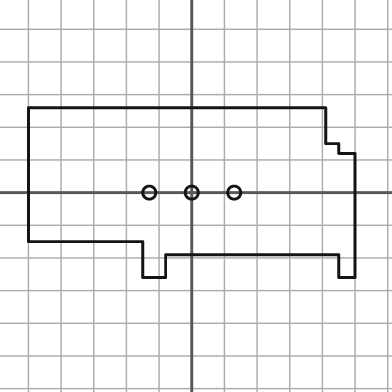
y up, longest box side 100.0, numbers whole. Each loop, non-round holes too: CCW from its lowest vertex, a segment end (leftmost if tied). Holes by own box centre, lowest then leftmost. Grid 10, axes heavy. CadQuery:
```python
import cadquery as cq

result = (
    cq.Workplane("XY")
    .moveTo(-15.0, -26.0)
    .lineTo(-8.0, -26.0)
    .lineTo(-8.0, -19.0)
    .lineTo(45.0, -19.0)
    .lineTo(45.0, -26.0)
    .lineTo(50.0, -26.0)
    .lineTo(50.0, 12.0)
    .lineTo(45.0, 12.0)
    .lineTo(45.0, 15.0)
    .lineTo(41.0, 15.0)
    .lineTo(41.0, 26.0)
    .lineTo(-50.0, 26.0)
    .lineTo(-50.0, -15.0)
    .lineTo(-15.0, -15.0)
    .close()
    .moveTo(-13.0, 0.0)
    .circle(2.0)
    .moveTo(0.0, 0.0)
    .circle(2.0)
    .moveTo(13.0, 0.0)
    .circle(2.0)
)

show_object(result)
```